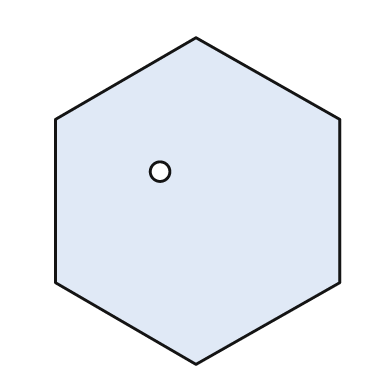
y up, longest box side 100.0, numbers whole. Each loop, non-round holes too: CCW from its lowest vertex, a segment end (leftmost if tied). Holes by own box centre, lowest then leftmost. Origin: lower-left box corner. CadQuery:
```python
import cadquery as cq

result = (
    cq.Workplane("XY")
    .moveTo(43.0, 0.0)
    .lineTo(87.0, 25.0)
    .lineTo(87.0, 75.0)
    .lineTo(43.0, 100.0)
    .lineTo(0.0, 75.0)
    .lineTo(0.0, 25.0)
    .close()
    .moveTo(32.0, 59.0)
    .circle(3.0)
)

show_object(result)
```